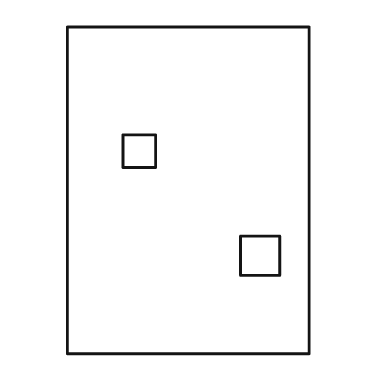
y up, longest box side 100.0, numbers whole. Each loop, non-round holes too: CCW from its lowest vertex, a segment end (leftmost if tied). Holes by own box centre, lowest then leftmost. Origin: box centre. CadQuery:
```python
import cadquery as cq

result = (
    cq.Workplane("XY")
    .moveTo(-37.0, -50.0)
    .lineTo(37.0, -50.0)
    .lineTo(37.0, 50.0)
    .lineTo(-37.0, 50.0)
    .close()
    .moveTo(16.0, -26.0)
    .lineTo(28.0, -26.0)
    .lineTo(28.0, -14.0)
    .lineTo(16.0, -14.0)
    .close()
    .moveTo(-20.0, 7.0)
    .lineTo(-10.0, 7.0)
    .lineTo(-10.0, 17.0)
    .lineTo(-20.0, 17.0)
    .close()
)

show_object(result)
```